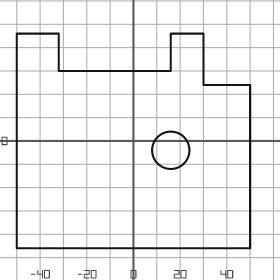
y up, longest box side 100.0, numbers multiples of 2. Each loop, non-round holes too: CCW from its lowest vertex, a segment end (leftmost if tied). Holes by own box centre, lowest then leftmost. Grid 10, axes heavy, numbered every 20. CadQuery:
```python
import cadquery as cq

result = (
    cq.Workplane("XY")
    .moveTo(-50.0, -46.0)
    .lineTo(50.0, -46.0)
    .lineTo(50.0, 24.0)
    .lineTo(30.0, 24.0)
    .lineTo(30.0, 46.0)
    .lineTo(16.0, 46.0)
    .lineTo(16.0, 30.0)
    .lineTo(-32.0, 30.0)
    .lineTo(-32.0, 46.0)
    .lineTo(-50.0, 46.0)
    .close()
    .moveTo(16.0, -4.0)
    .circle(8.0)
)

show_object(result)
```